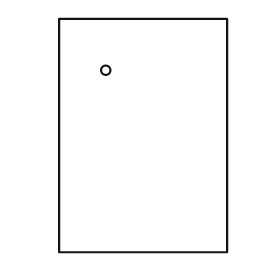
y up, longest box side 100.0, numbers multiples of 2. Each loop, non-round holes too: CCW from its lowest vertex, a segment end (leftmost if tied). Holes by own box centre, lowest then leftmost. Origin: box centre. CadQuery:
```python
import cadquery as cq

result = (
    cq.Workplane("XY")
    .moveTo(-36.0, -50.0)
    .lineTo(36.0, -50.0)
    .lineTo(36.0, 50.0)
    .lineTo(-36.0, 50.0)
    .close()
    .moveTo(-16.0, 28.0)
    .circle(2.0)
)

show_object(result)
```